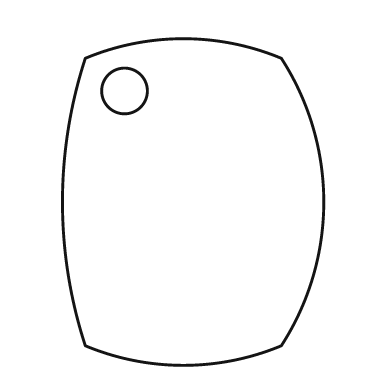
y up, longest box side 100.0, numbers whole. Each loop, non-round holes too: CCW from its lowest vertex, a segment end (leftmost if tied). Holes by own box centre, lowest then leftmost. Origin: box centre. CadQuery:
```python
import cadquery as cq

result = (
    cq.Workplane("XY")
    .moveTo(-33.0, -44.0)
    .threePointArc((-3.0, -50.0), (27.0, -44.0))
    .threePointArc((40.0, 0.0), (27.0, 44.0))
    .threePointArc((-3.0, 50.0), (-33.0, 44.0))
    .threePointArc((-40.0, 0.0), (-33.0, -44.0))
    .close()
    .moveTo(-21.0, 34.0)
    .circle(7.0)
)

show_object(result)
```